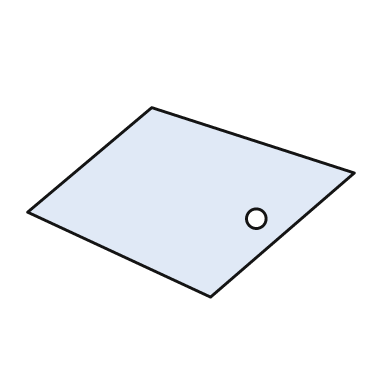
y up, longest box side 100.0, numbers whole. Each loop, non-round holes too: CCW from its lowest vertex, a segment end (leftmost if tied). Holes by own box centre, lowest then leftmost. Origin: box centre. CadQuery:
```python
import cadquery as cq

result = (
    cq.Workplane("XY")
    .moveTo(6.0, -29.0)
    .lineTo(50.0, 9.0)
    .lineTo(-12.0, 29.0)
    .lineTo(-50.0, -3.0)
    .close()
    .moveTo(20.0, -5.0)
    .circle(3.0)
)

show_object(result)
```